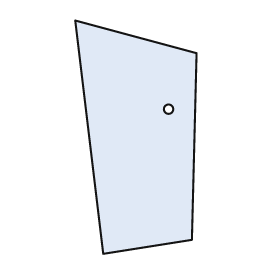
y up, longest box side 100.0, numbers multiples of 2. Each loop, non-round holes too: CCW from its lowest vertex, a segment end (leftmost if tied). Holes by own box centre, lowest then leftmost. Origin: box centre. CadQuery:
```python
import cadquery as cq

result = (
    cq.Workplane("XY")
    .moveTo(-14.0, -50.0)
    .lineTo(24.0, -44.0)
    .lineTo(26.0, 36.0)
    .lineTo(-26.0, 50.0)
    .close()
    .moveTo(14.0, 12.0)
    .circle(2.0)
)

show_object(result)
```